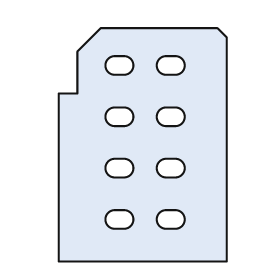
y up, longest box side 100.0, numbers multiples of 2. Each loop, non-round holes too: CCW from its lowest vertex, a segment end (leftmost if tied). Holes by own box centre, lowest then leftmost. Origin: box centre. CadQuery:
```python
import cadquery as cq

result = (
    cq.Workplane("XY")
    .moveTo(-36.0, -50.0)
    .lineTo(36.0, -50.0)
    .lineTo(36.0, 46.0)
    .lineTo(32.0, 50.0)
    .lineTo(-18.0, 50.0)
    .lineTo(-28.0, 40.0)
    .lineTo(-28.0, 22.0)
    .lineTo(-36.0, 22.0)
    .close()
    .moveTo(-12.0, -36.0)
    .lineTo(-8.0, -36.0)
    .threePointArc((-4.0, -32.0), (-8.0, -28.0))
    .lineTo(-12.0, -28.0)
    .threePointArc((-16.0, -32.0), (-12.0, -36.0))
    .close()
    .moveTo(10.0, -36.0)
    .lineTo(14.0, -36.0)
    .threePointArc((18.0, -32.0), (14.0, -28.0))
    .lineTo(10.0, -28.0)
    .threePointArc((6.0, -32.0), (10.0, -36.0))
    .close()
    .moveTo(-12.0, -14.0)
    .lineTo(-8.0, -14.0)
    .threePointArc((-4.0, -10.0), (-8.0, -6.0))
    .lineTo(-12.0, -6.0)
    .threePointArc((-16.0, -10.0), (-12.0, -14.0))
    .close()
    .moveTo(10.0, -14.0)
    .lineTo(14.0, -14.0)
    .threePointArc((18.0, -10.0), (14.0, -6.0))
    .lineTo(10.0, -6.0)
    .threePointArc((6.0, -10.0), (10.0, -14.0))
    .close()
    .moveTo(-12.0, 8.0)
    .lineTo(-8.0, 8.0)
    .threePointArc((-4.0, 12.0), (-8.0, 16.0))
    .lineTo(-12.0, 16.0)
    .threePointArc((-16.0, 12.0), (-12.0, 8.0))
    .close()
    .moveTo(10.0, 8.0)
    .lineTo(14.0, 8.0)
    .threePointArc((18.0, 12.0), (14.0, 16.0))
    .lineTo(10.0, 16.0)
    .threePointArc((6.0, 12.0), (10.0, 8.0))
    .close()
    .moveTo(-12.0, 30.0)
    .lineTo(-8.0, 30.0)
    .threePointArc((-4.0, 34.0), (-8.0, 38.0))
    .lineTo(-12.0, 38.0)
    .threePointArc((-16.0, 34.0), (-12.0, 30.0))
    .close()
    .moveTo(10.0, 30.0)
    .lineTo(14.0, 30.0)
    .threePointArc((18.0, 34.0), (14.0, 38.0))
    .lineTo(10.0, 38.0)
    .threePointArc((6.0, 34.0), (10.0, 30.0))
    .close()
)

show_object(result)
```